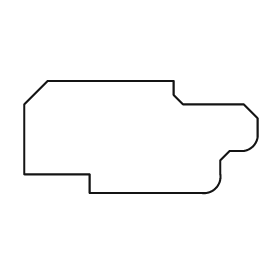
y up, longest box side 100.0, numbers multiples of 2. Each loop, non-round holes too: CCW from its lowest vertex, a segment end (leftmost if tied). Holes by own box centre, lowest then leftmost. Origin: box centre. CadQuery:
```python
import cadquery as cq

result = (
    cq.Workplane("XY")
    .moveTo(-22.0, -24.0)
    .lineTo(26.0, -24.0)
    .threePointArc((32.0, -22.0), (34.0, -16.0))
    .lineTo(34.0, -10.0)
    .lineTo(38.0, -6.0)
    .lineTo(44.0, -6.0)
    .threePointArc((48.0, -4.0), (50.0, 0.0))
    .lineTo(50.0, 8.0)
    .lineTo(44.0, 14.0)
    .lineTo(18.0, 14.0)
    .lineTo(14.0, 18.0)
    .lineTo(14.0, 24.0)
    .lineTo(-40.0, 24.0)
    .lineTo(-50.0, 14.0)
    .lineTo(-50.0, -16.0)
    .lineTo(-22.0, -16.0)
    .close()
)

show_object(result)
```